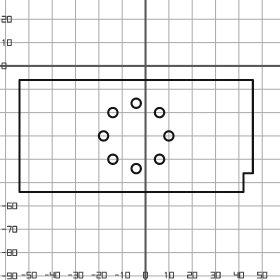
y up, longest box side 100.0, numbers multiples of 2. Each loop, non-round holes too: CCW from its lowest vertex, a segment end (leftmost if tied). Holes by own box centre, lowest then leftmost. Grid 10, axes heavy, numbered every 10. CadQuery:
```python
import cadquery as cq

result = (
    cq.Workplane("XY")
    .moveTo(-54.0, -54.0)
    .lineTo(42.0, -54.0)
    .lineTo(42.0, -46.0)
    .lineTo(46.0, -46.0)
    .lineTo(46.0, -6.0)
    .lineTo(-54.0, -6.0)
    .close()
    .moveTo(-4.0, -44.0)
    .circle(2.0)
    .moveTo(-14.0, -40.0)
    .circle(2.0)
    .moveTo(6.0, -40.0)
    .circle(2.0)
    .moveTo(-18.0, -30.0)
    .circle(2.0)
    .moveTo(10.0, -30.0)
    .circle(2.0)
    .moveTo(-14.0, -20.0)
    .circle(2.0)
    .moveTo(6.0, -20.0)
    .circle(2.0)
    .moveTo(-4.0, -16.0)
    .circle(2.0)
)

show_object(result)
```